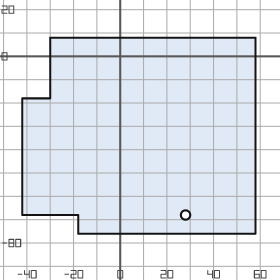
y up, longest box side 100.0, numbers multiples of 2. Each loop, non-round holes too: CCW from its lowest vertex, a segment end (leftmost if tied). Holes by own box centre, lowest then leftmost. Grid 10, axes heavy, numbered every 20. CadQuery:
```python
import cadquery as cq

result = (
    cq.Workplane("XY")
    .moveTo(-18.0, -76.0)
    .lineTo(58.0, -76.0)
    .lineTo(58.0, 8.0)
    .lineTo(-30.0, 8.0)
    .lineTo(-30.0, -18.0)
    .lineTo(-42.0, -18.0)
    .lineTo(-42.0, -68.0)
    .lineTo(-18.0, -68.0)
    .close()
    .moveTo(28.0, -68.0)
    .circle(2.0)
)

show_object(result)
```